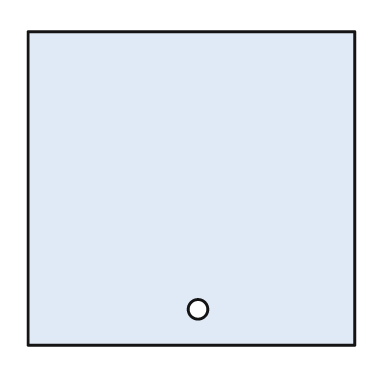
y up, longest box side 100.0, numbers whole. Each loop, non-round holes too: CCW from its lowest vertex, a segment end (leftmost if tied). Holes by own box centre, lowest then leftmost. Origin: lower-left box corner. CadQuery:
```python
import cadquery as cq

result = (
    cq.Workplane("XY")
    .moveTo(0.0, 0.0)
    .lineTo(100.0, 0.0)
    .lineTo(100.0, 96.0)
    .lineTo(0.0, 96.0)
    .close()
    .moveTo(52.0, 11.0)
    .circle(3.0)
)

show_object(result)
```